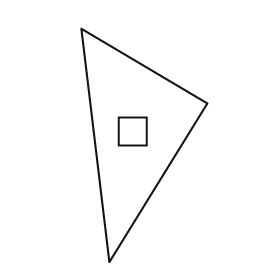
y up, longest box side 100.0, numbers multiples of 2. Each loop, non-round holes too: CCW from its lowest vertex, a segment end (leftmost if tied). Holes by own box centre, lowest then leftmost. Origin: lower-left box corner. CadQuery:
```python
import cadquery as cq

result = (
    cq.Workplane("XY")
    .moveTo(12.0, 0.0)
    .lineTo(54.0, 68.0)
    .lineTo(0.0, 100.0)
    .close()
    .moveTo(16.0, 50.0)
    .lineTo(28.0, 50.0)
    .lineTo(28.0, 62.0)
    .lineTo(16.0, 62.0)
    .close()
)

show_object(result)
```